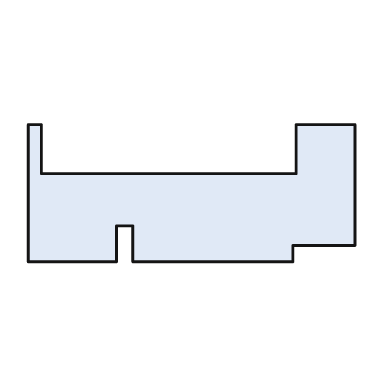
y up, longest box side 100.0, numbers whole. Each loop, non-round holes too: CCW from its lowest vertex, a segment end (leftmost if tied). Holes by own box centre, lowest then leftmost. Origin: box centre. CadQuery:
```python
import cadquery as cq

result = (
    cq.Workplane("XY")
    .moveTo(-50.0, -21.0)
    .lineTo(-23.0, -21.0)
    .lineTo(-23.0, -10.0)
    .lineTo(-18.0, -10.0)
    .lineTo(-18.0, -21.0)
    .lineTo(31.0, -21.0)
    .lineTo(31.0, -16.0)
    .lineTo(50.0, -16.0)
    .lineTo(50.0, 21.0)
    .lineTo(32.0, 21.0)
    .lineTo(32.0, 6.0)
    .lineTo(-46.0, 6.0)
    .lineTo(-46.0, 21.0)
    .lineTo(-50.0, 21.0)
    .close()
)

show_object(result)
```